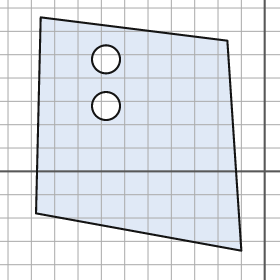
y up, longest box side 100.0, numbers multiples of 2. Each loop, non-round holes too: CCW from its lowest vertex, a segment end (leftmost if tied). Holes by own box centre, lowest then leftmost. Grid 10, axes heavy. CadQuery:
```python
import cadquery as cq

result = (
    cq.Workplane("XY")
    .moveTo(-10.0, -34.0)
    .lineTo(-16.0, 56.0)
    .lineTo(-96.0, 66.0)
    .lineTo(-98.0, -18.0)
    .close()
    .moveTo(-68.0, 28.0)
    .circle(6.0)
    .moveTo(-68.0, 48.0)
    .circle(6.0)
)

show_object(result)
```